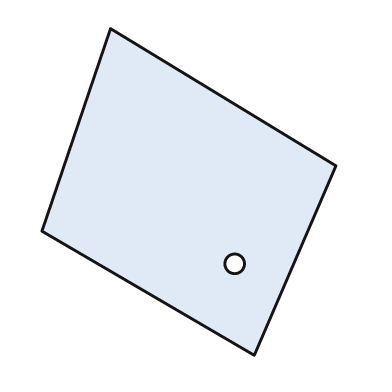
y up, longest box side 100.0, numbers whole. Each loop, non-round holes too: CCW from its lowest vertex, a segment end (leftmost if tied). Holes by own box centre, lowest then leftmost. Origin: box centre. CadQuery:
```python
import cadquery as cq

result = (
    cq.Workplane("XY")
    .moveTo(20.0, -50.0)
    .lineTo(45.0, 8.0)
    .lineTo(-24.0, 50.0)
    .lineTo(-45.0, -12.0)
    .close()
    .moveTo(14.0, -22.0)
    .circle(3.0)
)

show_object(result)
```